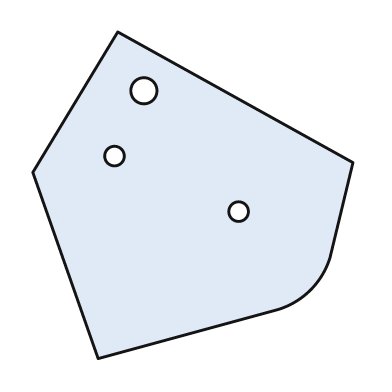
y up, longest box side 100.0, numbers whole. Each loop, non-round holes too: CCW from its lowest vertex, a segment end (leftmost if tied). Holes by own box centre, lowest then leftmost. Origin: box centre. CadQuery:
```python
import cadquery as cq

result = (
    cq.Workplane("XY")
    .moveTo(-29.0, -50.0)
    .lineTo(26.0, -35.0)
    .threePointArc((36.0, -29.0), (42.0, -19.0))
    .lineTo(49.0, 10.0)
    .lineTo(-23.0, 50.0)
    .lineTo(-49.0, 7.0)
    .close()
    .moveTo(14.0, -5.0)
    .circle(3.0)
    .moveTo(-24.0, 12.0)
    .circle(3.0)
    .moveTo(-15.0, 32.0)
    .circle(4.0)
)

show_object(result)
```